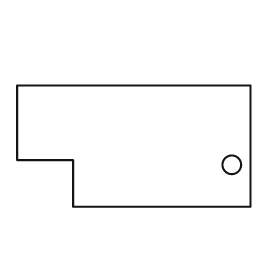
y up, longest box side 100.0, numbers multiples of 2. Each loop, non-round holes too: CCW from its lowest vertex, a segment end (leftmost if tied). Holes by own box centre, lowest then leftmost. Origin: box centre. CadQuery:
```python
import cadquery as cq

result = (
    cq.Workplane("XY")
    .moveTo(-26.0, -26.0)
    .lineTo(50.0, -26.0)
    .lineTo(50.0, 26.0)
    .lineTo(-50.0, 26.0)
    .lineTo(-50.0, -6.0)
    .lineTo(-26.0, -6.0)
    .close()
    .moveTo(42.0, -8.0)
    .circle(4.0)
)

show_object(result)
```